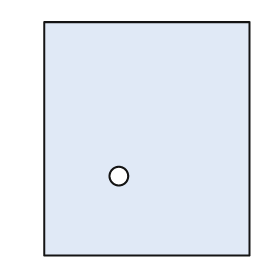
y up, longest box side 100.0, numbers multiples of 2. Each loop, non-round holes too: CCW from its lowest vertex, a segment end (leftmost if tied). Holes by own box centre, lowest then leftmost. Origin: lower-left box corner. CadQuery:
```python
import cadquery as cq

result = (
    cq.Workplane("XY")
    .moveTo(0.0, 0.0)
    .lineTo(88.0, 0.0)
    .lineTo(88.0, 100.0)
    .lineTo(0.0, 100.0)
    .close()
    .moveTo(32.0, 34.0)
    .circle(4.0)
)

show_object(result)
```